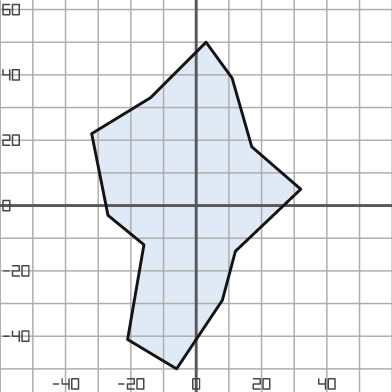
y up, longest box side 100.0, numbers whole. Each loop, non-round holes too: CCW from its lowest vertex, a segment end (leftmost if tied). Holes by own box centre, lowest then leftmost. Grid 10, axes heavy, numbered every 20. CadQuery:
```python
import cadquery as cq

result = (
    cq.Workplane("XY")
    .moveTo(-6.0, -50.0)
    .lineTo(8.0, -29.0)
    .lineTo(12.0, -14.0)
    .lineTo(32.0, 5.0)
    .lineTo(17.0, 18.0)
    .lineTo(11.0, 39.0)
    .lineTo(3.0, 50.0)
    .lineTo(-14.0, 33.0)
    .lineTo(-32.0, 22.0)
    .lineTo(-27.0, -3.0)
    .lineTo(-16.0, -12.0)
    .lineTo(-21.0, -41.0)
    .close()
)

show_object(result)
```